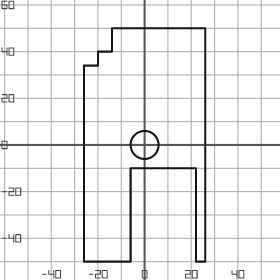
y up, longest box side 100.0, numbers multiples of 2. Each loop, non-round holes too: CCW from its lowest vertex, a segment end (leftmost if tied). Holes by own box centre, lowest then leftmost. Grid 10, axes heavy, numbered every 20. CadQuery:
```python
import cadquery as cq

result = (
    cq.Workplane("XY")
    .moveTo(-26.0, -50.0)
    .lineTo(-6.0, -50.0)
    .lineTo(-6.0, -10.0)
    .lineTo(22.0, -10.0)
    .lineTo(22.0, -50.0)
    .lineTo(26.0, -50.0)
    .lineTo(26.0, 50.0)
    .lineTo(-14.0, 50.0)
    .lineTo(-14.0, 40.0)
    .lineTo(-20.0, 40.0)
    .lineTo(-20.0, 34.0)
    .lineTo(-26.0, 34.0)
    .close()
    .moveTo(0.0, 0.0)
    .circle(6.0)
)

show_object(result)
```